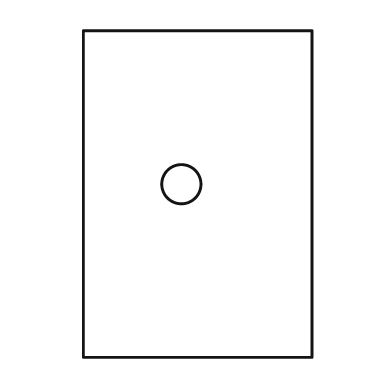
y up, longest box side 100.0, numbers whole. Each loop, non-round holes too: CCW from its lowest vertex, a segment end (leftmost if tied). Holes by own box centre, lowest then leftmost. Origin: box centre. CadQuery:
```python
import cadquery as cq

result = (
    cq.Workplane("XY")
    .moveTo(-35.0, -50.0)
    .lineTo(35.0, -50.0)
    .lineTo(35.0, 50.0)
    .lineTo(-35.0, 50.0)
    .close()
    .moveTo(-5.0, 3.0)
    .circle(6.0)
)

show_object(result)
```